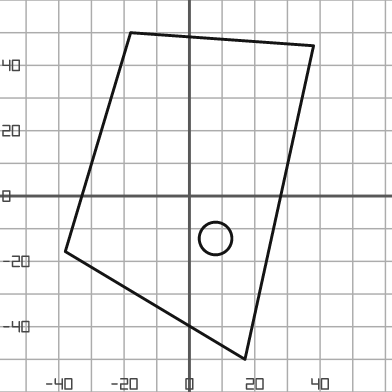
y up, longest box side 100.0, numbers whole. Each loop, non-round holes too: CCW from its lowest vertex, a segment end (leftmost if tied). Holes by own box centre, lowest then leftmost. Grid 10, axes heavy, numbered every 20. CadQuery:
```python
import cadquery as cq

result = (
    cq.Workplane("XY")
    .moveTo(17.0, -50.0)
    .lineTo(38.0, 46.0)
    .lineTo(-18.0, 50.0)
    .lineTo(-38.0, -17.0)
    .close()
    .moveTo(8.0, -13.0)
    .circle(5.0)
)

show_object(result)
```